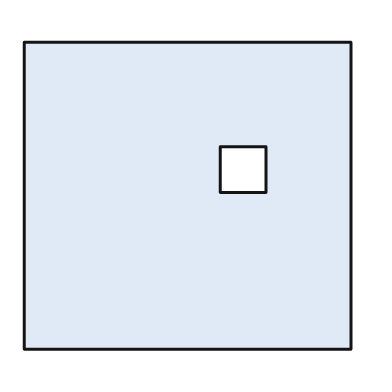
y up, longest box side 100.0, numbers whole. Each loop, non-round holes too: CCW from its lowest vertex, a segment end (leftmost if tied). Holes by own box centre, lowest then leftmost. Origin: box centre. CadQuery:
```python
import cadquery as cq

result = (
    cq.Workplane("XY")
    .moveTo(-50.0, -47.0)
    .lineTo(50.0, -47.0)
    .lineTo(50.0, 47.0)
    .lineTo(-50.0, 47.0)
    .close()
    .moveTo(10.0, 1.0)
    .lineTo(24.0, 1.0)
    .lineTo(24.0, 15.0)
    .lineTo(10.0, 15.0)
    .close()
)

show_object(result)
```